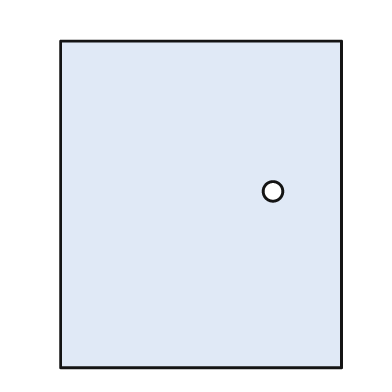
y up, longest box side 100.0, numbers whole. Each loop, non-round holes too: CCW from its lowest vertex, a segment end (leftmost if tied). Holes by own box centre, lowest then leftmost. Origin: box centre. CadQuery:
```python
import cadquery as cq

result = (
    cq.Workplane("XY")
    .moveTo(-43.0, -50.0)
    .lineTo(43.0, -50.0)
    .lineTo(43.0, 50.0)
    .lineTo(-43.0, 50.0)
    .close()
    .moveTo(22.0, 4.0)
    .circle(3.0)
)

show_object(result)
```